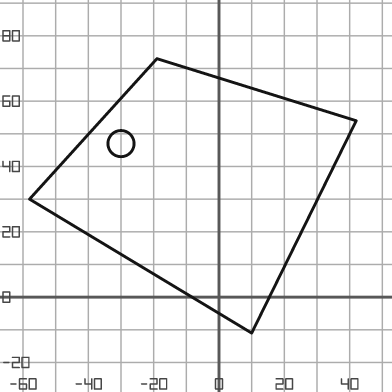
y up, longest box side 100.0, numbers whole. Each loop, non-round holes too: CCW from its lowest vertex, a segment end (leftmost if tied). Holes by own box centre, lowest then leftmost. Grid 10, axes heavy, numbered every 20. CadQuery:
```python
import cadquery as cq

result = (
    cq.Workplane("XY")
    .moveTo(10.0, -11.0)
    .lineTo(42.0, 54.0)
    .lineTo(-19.0, 73.0)
    .lineTo(-58.0, 30.0)
    .close()
    .moveTo(-30.0, 47.0)
    .circle(4.0)
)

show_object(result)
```